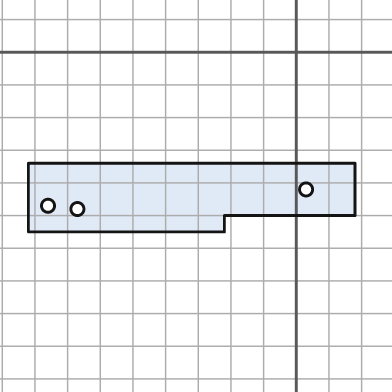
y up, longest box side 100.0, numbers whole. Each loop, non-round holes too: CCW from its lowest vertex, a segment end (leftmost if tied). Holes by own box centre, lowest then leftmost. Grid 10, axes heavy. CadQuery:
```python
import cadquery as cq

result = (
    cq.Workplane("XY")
    .moveTo(-82.0, -55.0)
    .lineTo(-22.0, -55.0)
    .lineTo(-22.0, -50.0)
    .lineTo(18.0, -50.0)
    .lineTo(18.0, -34.0)
    .lineTo(-82.0, -34.0)
    .close()
    .moveTo(-67.0, -48.0)
    .circle(2.0)
    .moveTo(-76.0, -47.0)
    .circle(2.0)
    .moveTo(3.0, -42.0)
    .circle(2.0)
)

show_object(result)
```